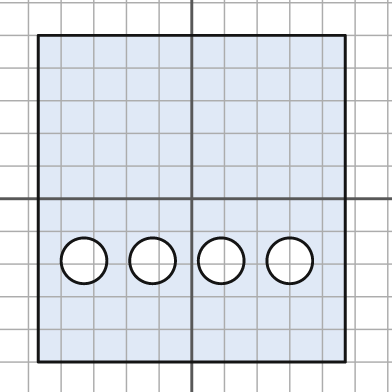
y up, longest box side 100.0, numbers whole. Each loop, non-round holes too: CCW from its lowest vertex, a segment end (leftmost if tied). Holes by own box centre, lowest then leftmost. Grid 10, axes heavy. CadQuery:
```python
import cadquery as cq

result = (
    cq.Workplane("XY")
    .moveTo(-47.0, -50.0)
    .lineTo(47.0, -50.0)
    .lineTo(47.0, 50.0)
    .lineTo(-47.0, 50.0)
    .close()
    .moveTo(-33.0, -19.0)
    .circle(7.0)
    .moveTo(-12.0, -19.0)
    .circle(7.0)
    .moveTo(9.0, -19.0)
    .circle(7.0)
    .moveTo(30.0, -19.0)
    .circle(7.0)
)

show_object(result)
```